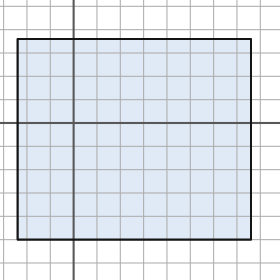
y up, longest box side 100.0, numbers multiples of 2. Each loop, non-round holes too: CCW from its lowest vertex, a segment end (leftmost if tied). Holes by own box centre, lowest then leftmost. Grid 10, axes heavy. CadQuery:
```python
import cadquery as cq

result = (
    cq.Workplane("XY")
    .moveTo(-24.0, -50.0)
    .lineTo(76.0, -50.0)
    .lineTo(76.0, 36.0)
    .lineTo(-24.0, 36.0)
    .close()
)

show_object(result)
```